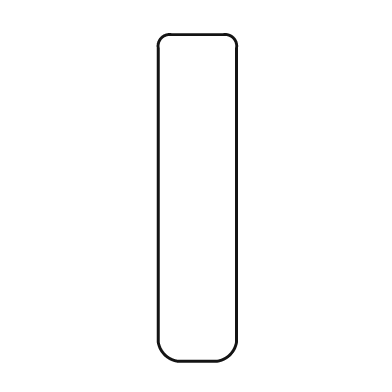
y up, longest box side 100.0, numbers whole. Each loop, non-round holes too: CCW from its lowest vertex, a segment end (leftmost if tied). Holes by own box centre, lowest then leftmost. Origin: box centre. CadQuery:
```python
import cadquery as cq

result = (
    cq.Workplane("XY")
    .moveTo(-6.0, -50.0)
    .lineTo(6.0, -50.0)
    .threePointArc((10.0, -48.0), (12.0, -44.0))
    .lineTo(12.0, 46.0)
    .threePointArc((11.0, 49.0), (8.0, 50.0))
    .lineTo(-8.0, 50.0)
    .threePointArc((-11.0, 49.0), (-12.0, 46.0))
    .lineTo(-12.0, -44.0)
    .threePointArc((-10.0, -48.0), (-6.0, -50.0))
    .close()
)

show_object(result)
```